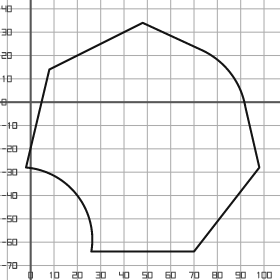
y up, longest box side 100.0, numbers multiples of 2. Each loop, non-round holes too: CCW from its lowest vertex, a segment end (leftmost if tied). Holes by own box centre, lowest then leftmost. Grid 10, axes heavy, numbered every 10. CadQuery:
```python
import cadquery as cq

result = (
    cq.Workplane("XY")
    .moveTo(26.0, -64.0)
    .lineTo(70.0, -64.0)
    .lineTo(98.0, -28.0)
    .lineTo(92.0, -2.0)
    .threePointArc((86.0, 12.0), (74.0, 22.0))
    .lineTo(48.0, 34.0)
    .lineTo(8.0, 14.0)
    .lineTo(-2.0, -28.0)
    .threePointArc((20.0, -40.0), (26.0, -64.0))
    .close()
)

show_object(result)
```